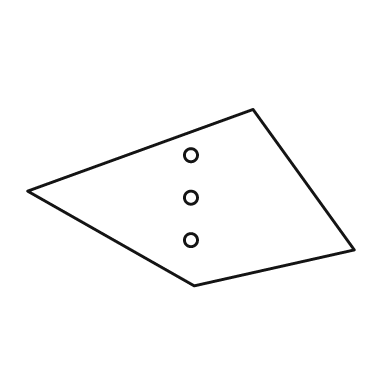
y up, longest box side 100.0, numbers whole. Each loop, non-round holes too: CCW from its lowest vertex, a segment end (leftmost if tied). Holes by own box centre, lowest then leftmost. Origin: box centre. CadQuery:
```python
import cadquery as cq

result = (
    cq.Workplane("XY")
    .moveTo(1.0, -27.0)
    .lineTo(50.0, -16.0)
    .lineTo(19.0, 27.0)
    .lineTo(-50.0, 2.0)
    .close()
    .moveTo(0.0, -13.0)
    .circle(2.0)
    .moveTo(0.0, 0.0)
    .circle(2.0)
    .moveTo(0.0, 13.0)
    .circle(2.0)
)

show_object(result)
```